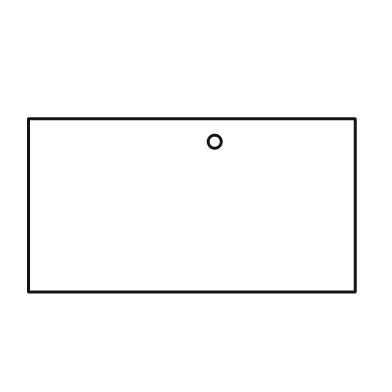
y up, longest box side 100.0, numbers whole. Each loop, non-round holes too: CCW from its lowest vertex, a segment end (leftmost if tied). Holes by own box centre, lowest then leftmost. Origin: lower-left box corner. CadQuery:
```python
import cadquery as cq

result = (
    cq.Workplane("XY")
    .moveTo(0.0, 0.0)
    .lineTo(100.0, 0.0)
    .lineTo(100.0, 53.0)
    .lineTo(0.0, 53.0)
    .close()
    .moveTo(57.0, 46.0)
    .circle(2.0)
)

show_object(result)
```